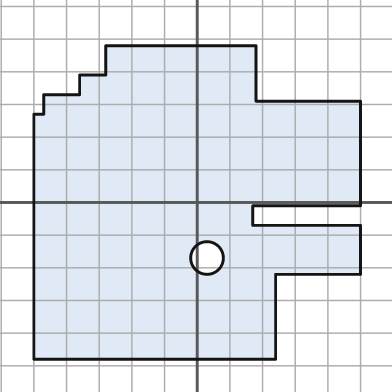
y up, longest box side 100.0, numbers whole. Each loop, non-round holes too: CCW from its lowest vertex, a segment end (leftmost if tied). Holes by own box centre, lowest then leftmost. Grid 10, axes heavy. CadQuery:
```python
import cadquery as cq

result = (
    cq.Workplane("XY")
    .moveTo(-50.0, -48.0)
    .lineTo(24.0, -48.0)
    .lineTo(24.0, -22.0)
    .lineTo(50.0, -22.0)
    .lineTo(50.0, -7.0)
    .lineTo(17.0, -7.0)
    .lineTo(17.0, -1.0)
    .lineTo(50.0, -1.0)
    .lineTo(50.0, 31.0)
    .lineTo(18.0, 31.0)
    .lineTo(18.0, 48.0)
    .lineTo(-28.0, 48.0)
    .lineTo(-28.0, 39.0)
    .lineTo(-36.0, 39.0)
    .lineTo(-36.0, 33.0)
    .lineTo(-47.0, 33.0)
    .lineTo(-47.0, 27.0)
    .lineTo(-50.0, 27.0)
    .close()
    .moveTo(3.0, -17.0)
    .circle(5.0)
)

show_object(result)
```